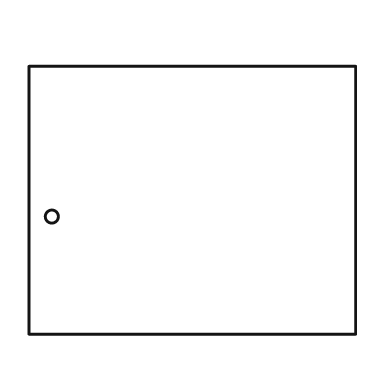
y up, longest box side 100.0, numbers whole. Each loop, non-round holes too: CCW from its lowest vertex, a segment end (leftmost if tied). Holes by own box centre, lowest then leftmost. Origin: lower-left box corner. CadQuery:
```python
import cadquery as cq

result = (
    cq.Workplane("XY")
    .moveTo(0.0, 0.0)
    .lineTo(100.0, 0.0)
    .lineTo(100.0, 82.0)
    .lineTo(0.0, 82.0)
    .close()
    .moveTo(7.0, 36.0)
    .circle(2.0)
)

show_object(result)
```